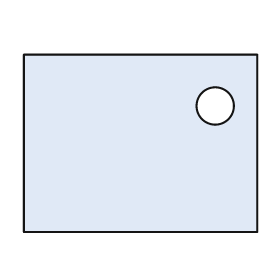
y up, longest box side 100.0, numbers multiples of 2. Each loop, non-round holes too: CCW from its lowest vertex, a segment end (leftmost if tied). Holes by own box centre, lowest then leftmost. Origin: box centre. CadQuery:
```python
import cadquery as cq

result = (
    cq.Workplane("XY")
    .moveTo(-50.0, -38.0)
    .lineTo(50.0, -38.0)
    .lineTo(50.0, 38.0)
    .lineTo(-50.0, 38.0)
    .close()
    .moveTo(32.0, 16.0)
    .circle(8.0)
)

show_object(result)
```